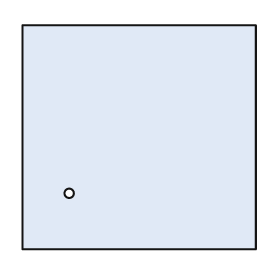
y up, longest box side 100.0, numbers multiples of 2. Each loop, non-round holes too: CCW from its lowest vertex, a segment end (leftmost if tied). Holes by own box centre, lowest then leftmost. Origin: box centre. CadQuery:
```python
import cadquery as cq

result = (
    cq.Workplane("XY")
    .moveTo(-50.0, -48.0)
    .lineTo(50.0, -48.0)
    .lineTo(50.0, 48.0)
    .lineTo(-50.0, 48.0)
    .close()
    .moveTo(-30.0, -24.0)
    .circle(2.0)
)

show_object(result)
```